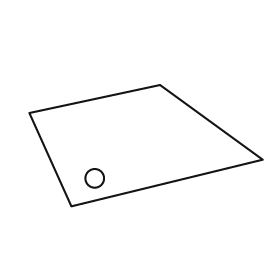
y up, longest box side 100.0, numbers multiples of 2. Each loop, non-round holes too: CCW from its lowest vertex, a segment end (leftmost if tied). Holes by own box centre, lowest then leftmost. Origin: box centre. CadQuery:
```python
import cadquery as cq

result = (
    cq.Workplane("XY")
    .moveTo(-32.0, -26.0)
    .lineTo(50.0, -6.0)
    .lineTo(6.0, 26.0)
    .lineTo(-50.0, 14.0)
    .close()
    .moveTo(-22.0, -14.0)
    .circle(4.0)
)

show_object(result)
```